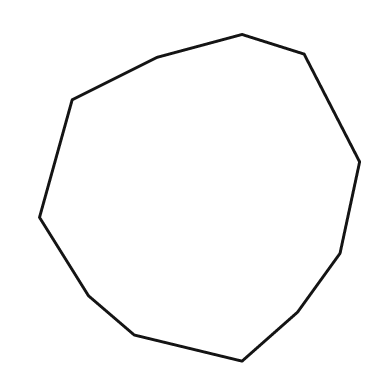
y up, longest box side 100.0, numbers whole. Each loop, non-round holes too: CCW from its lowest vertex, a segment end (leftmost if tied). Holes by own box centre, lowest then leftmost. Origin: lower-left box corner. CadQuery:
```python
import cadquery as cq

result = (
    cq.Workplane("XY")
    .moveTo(62.0, 0.0)
    .lineTo(79.0, 15.0)
    .lineTo(92.0, 33.0)
    .lineTo(98.0, 61.0)
    .lineTo(81.0, 94.0)
    .lineTo(62.0, 100.0)
    .lineTo(36.0, 93.0)
    .lineTo(10.0, 80.0)
    .lineTo(0.0, 44.0)
    .lineTo(15.0, 20.0)
    .lineTo(29.0, 8.0)
    .close()
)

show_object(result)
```